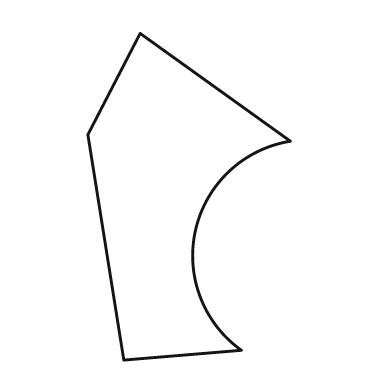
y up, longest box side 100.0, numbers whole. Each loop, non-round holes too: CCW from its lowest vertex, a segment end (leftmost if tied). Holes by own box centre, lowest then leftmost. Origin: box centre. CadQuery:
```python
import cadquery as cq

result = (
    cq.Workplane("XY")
    .moveTo(-20.0, -50.0)
    .lineTo(16.0, -47.0)
    .threePointArc((2.0, -10.0), (31.0, 17.0))
    .lineTo(-15.0, 50.0)
    .lineTo(-31.0, 19.0)
    .close()
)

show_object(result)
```